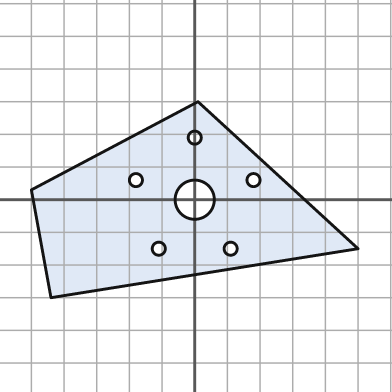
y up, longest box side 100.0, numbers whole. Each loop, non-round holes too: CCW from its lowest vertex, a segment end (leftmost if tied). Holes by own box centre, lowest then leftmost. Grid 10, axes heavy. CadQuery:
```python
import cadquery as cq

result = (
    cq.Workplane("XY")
    .moveTo(-44.0, -30.0)
    .lineTo(50.0, -15.0)
    .lineTo(1.0, 30.0)
    .lineTo(-50.0, 3.0)
    .close()
    .moveTo(-11.0, -15.0)
    .circle(2.0)
    .moveTo(11.0, -15.0)
    .circle(2.0)
    .moveTo(0.0, 0.0)
    .circle(6.0)
    .moveTo(-18.0, 6.0)
    .circle(2.0)
    .moveTo(18.0, 6.0)
    .circle(2.0)
    .moveTo(0.0, 19.0)
    .circle(2.0)
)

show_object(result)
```